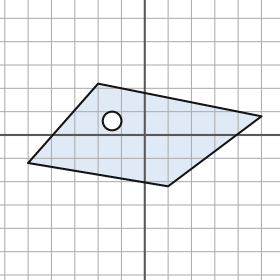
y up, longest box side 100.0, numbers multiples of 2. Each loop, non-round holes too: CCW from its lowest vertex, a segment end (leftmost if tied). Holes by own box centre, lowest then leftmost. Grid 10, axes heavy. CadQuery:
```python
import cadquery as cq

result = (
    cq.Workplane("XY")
    .moveTo(10.0, -22.0)
    .lineTo(50.0, 8.0)
    .lineTo(-20.0, 22.0)
    .lineTo(-50.0, -12.0)
    .close()
    .moveTo(-14.0, 6.0)
    .circle(4.0)
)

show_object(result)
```